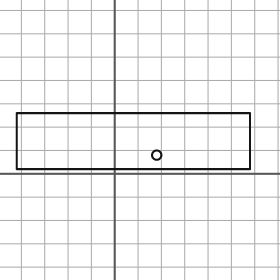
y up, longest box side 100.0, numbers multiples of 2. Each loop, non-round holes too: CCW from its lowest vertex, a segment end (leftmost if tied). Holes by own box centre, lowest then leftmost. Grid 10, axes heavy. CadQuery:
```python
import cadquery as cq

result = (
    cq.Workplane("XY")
    .moveTo(-42.0, 2.0)
    .lineTo(58.0, 2.0)
    .lineTo(58.0, 26.0)
    .lineTo(-42.0, 26.0)
    .close()
    .moveTo(18.0, 8.0)
    .circle(2.0)
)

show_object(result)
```